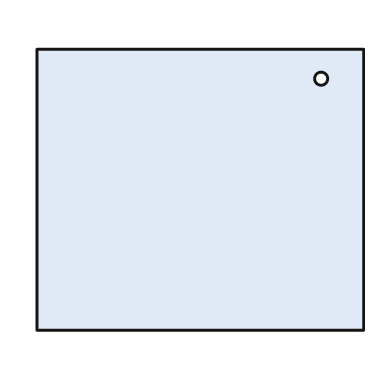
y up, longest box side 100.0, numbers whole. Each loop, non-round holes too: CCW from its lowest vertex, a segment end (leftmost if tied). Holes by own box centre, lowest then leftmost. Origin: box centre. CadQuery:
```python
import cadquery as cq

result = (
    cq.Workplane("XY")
    .moveTo(-50.0, -43.0)
    .lineTo(50.0, -43.0)
    .lineTo(50.0, 43.0)
    .lineTo(-50.0, 43.0)
    .close()
    .moveTo(37.0, 34.0)
    .circle(2.0)
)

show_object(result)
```